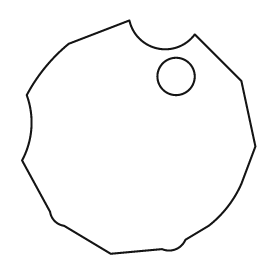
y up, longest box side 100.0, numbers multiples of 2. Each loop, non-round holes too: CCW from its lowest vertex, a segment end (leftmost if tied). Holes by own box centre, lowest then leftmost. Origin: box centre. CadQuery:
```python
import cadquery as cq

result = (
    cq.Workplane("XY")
    .moveTo(-12.0, -50.0)
    .lineTo(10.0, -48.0)
    .threePointArc((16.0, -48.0), (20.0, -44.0))
    .lineTo(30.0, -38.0)
    .threePointArc((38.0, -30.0), (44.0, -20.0))
    .lineTo(50.0, -4.0)
    .lineTo(44.0, 24.0)
    .lineTo(24.0, 44.0)
    .threePointArc((8.0, 38.0), (-4.0, 50.0))
    .lineTo(-30.0, 40.0)
    .threePointArc((-40.0, 30.0), (-48.0, 18.0))
    .threePointArc((-46.0, 4.0), (-50.0, -10.0))
    .lineTo(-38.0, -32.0)
    .threePointArc((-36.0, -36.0), (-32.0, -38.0))
    .close()
    .moveTo(16.0, 26.0)
    .circle(8.0)
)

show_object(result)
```